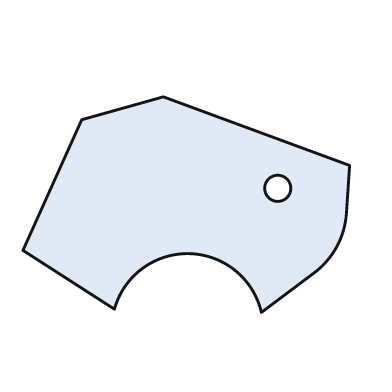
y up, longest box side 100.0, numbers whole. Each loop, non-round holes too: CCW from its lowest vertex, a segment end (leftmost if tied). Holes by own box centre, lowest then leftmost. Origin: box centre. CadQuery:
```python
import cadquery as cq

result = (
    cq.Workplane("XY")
    .moveTo(23.0, -33.0)
    .lineTo(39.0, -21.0)
    .threePointArc((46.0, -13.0), (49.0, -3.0))
    .lineTo(50.0, 12.0)
    .lineTo(-7.0, 33.0)
    .lineTo(-32.0, 26.0)
    .lineTo(-50.0, -14.0)
    .lineTo(-22.0, -32.0)
    .threePointArc((1.0, -15.0), (23.0, -33.0))
    .close()
    .moveTo(28.0, 5.0)
    .circle(4.0)
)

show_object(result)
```